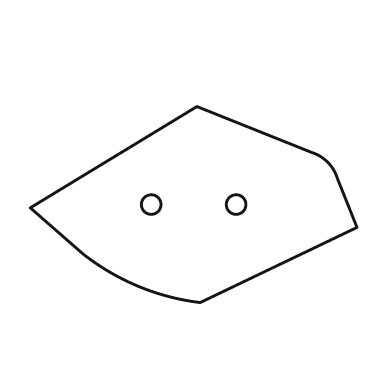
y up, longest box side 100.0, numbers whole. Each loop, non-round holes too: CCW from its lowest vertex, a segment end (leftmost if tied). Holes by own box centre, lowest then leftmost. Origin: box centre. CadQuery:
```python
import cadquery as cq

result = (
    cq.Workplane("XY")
    .moveTo(2.0, -30.0)
    .lineTo(50.0, -7.0)
    .lineTo(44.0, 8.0)
    .threePointArc((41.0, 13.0), (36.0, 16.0))
    .lineTo(1.0, 30.0)
    .lineTo(-50.0, -1.0)
    .lineTo(-34.0, -15.0)
    .threePointArc((-17.0, -25.0), (2.0, -30.0))
    .close()
    .moveTo(-13.0, 0.0)
    .circle(3.0)
    .moveTo(13.0, 0.0)
    .circle(3.0)
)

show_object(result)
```